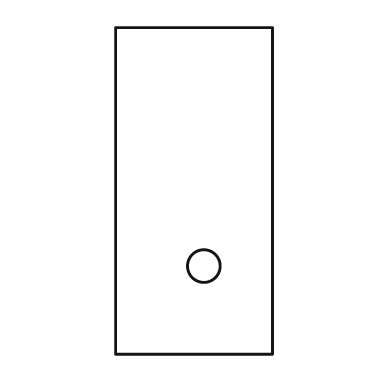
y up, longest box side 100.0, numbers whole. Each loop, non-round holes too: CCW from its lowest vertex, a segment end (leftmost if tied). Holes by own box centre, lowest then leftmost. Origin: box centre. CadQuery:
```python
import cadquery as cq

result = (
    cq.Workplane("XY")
    .moveTo(-24.0, -50.0)
    .lineTo(24.0, -50.0)
    .lineTo(24.0, 50.0)
    .lineTo(-24.0, 50.0)
    .close()
    .moveTo(3.0, -23.0)
    .circle(5.0)
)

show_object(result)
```